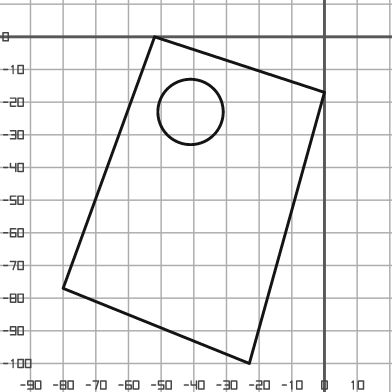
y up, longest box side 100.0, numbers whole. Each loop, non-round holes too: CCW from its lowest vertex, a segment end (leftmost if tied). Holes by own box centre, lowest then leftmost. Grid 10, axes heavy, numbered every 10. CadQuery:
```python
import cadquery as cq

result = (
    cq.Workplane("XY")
    .moveTo(-23.0, -100.0)
    .lineTo(0.0, -17.0)
    .lineTo(-52.0, 0.0)
    .lineTo(-80.0, -77.0)
    .close()
    .moveTo(-41.0, -23.0)
    .circle(10.0)
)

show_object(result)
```